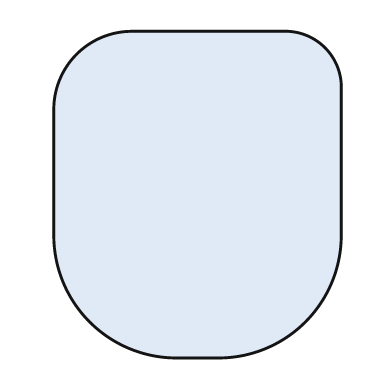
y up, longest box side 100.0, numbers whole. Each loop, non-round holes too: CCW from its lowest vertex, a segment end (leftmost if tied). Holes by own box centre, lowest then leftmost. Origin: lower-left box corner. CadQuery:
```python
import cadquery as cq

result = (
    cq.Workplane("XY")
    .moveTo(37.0, 0.0)
    .lineTo(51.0, 0.0)
    .threePointArc((77.0, 11.0), (88.0, 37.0))
    .lineTo(88.0, 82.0)
    .threePointArc((83.0, 95.0), (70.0, 100.0))
    .lineTo(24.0, 100.0)
    .threePointArc((7.0, 93.0), (0.0, 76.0))
    .lineTo(0.0, 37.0)
    .threePointArc((11.0, 11.0), (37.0, 0.0))
    .close()
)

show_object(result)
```